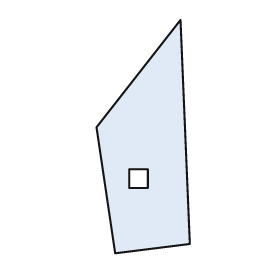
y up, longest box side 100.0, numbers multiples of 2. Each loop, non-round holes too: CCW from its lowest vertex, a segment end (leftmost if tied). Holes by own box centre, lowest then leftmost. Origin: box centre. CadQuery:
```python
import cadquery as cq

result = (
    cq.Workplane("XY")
    .moveTo(-12.0, -50.0)
    .lineTo(20.0, -46.0)
    .lineTo(16.0, 50.0)
    .lineTo(-20.0, 4.0)
    .close()
    .moveTo(-6.0, -22.0)
    .lineTo(2.0, -22.0)
    .lineTo(2.0, -14.0)
    .lineTo(-6.0, -14.0)
    .close()
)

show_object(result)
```